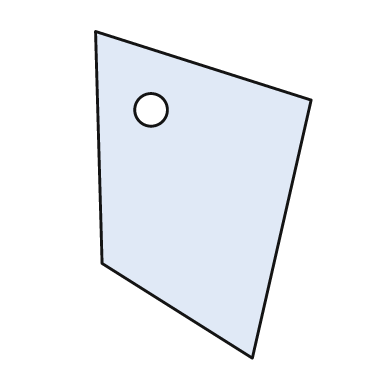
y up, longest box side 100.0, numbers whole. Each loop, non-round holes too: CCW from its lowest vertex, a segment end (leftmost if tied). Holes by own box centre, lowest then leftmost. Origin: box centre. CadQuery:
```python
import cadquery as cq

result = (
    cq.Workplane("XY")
    .moveTo(15.0, -50.0)
    .lineTo(33.0, 29.0)
    .lineTo(-33.0, 50.0)
    .lineTo(-31.0, -21.0)
    .close()
    .moveTo(-16.0, 26.0)
    .circle(5.0)
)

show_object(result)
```